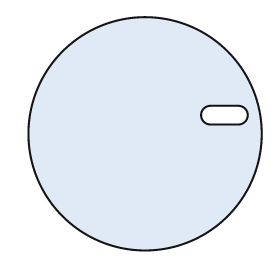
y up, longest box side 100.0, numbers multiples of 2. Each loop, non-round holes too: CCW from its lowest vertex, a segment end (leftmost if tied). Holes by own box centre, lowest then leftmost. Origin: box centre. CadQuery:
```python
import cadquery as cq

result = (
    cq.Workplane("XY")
    .moveTo(0.0, 0.0)
    .circle(50.0)
    .moveTo(28.0, 4.0)
    .lineTo(40.0, 4.0)
    .threePointArc((44.0, 8.0), (40.0, 12.0))
    .lineTo(28.0, 12.0)
    .threePointArc((24.0, 8.0), (28.0, 4.0))
    .close()
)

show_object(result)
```